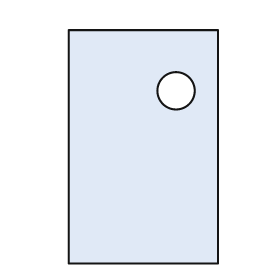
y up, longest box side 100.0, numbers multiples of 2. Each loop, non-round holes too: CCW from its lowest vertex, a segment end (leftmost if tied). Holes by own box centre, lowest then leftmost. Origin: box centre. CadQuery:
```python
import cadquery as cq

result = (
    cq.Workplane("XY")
    .moveTo(-32.0, -50.0)
    .lineTo(32.0, -50.0)
    .lineTo(32.0, 50.0)
    .lineTo(-32.0, 50.0)
    .close()
    .moveTo(14.0, 24.0)
    .circle(8.0)
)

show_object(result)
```